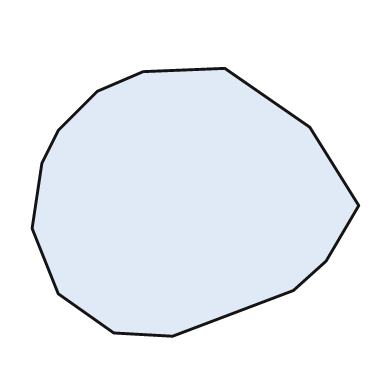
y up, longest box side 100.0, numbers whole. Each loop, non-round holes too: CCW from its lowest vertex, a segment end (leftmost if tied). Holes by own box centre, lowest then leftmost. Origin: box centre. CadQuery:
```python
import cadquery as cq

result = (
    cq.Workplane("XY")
    .moveTo(-7.0, -41.0)
    .lineTo(30.0, -27.0)
    .lineTo(40.0, -18.0)
    .lineTo(50.0, -1.0)
    .lineTo(35.0, 23.0)
    .lineTo(9.0, 41.0)
    .lineTo(-16.0, 40.0)
    .lineTo(-30.0, 34.0)
    .lineTo(-42.0, 22.0)
    .lineTo(-47.0, 12.0)
    .lineTo(-50.0, -8.0)
    .lineTo(-42.0, -28.0)
    .lineTo(-25.0, -40.0)
    .close()
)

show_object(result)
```